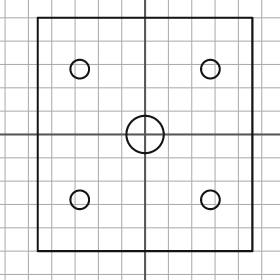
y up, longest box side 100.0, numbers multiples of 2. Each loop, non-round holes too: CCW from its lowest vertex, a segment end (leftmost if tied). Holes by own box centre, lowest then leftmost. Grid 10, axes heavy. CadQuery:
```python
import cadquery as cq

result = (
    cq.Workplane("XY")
    .moveTo(-46.0, -50.0)
    .lineTo(46.0, -50.0)
    .lineTo(46.0, 50.0)
    .lineTo(-46.0, 50.0)
    .close()
    .moveTo(-28.0, -28.0)
    .circle(4.0)
    .moveTo(28.0, -28.0)
    .circle(4.0)
    .moveTo(0.0, 0.0)
    .circle(8.0)
    .moveTo(-28.0, 28.0)
    .circle(4.0)
    .moveTo(28.0, 28.0)
    .circle(4.0)
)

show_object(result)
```